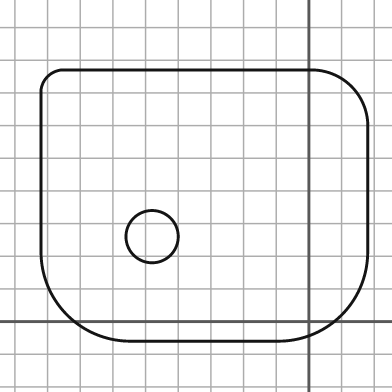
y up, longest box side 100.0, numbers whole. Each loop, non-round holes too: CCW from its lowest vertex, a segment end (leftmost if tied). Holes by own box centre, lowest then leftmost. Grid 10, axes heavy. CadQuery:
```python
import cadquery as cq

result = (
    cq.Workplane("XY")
    .moveTo(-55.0, -6.0)
    .lineTo(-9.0, -6.0)
    .threePointArc((10.0, 2.0), (18.0, 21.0))
    .lineTo(18.0, 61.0)
    .threePointArc((13.0, 72.0), (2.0, 77.0))
    .lineTo(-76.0, 77.0)
    .threePointArc((-80.0, 75.0), (-82.0, 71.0))
    .lineTo(-82.0, 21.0)
    .threePointArc((-74.0, 2.0), (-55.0, -6.0))
    .close()
    .moveTo(-48.0, 26.0)
    .circle(8.0)
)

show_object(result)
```